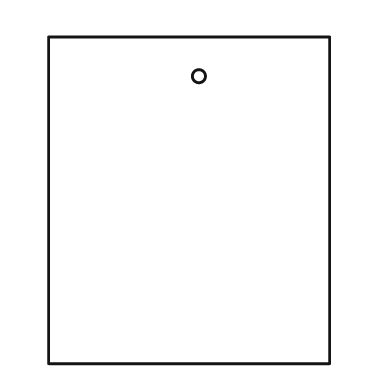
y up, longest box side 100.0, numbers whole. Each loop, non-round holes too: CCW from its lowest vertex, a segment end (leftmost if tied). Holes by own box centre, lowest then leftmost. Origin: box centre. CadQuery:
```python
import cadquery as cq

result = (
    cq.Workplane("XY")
    .moveTo(-43.0, -50.0)
    .lineTo(43.0, -50.0)
    .lineTo(43.0, 50.0)
    .lineTo(-43.0, 50.0)
    .close()
    .moveTo(3.0, 38.0)
    .circle(2.0)
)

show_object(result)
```